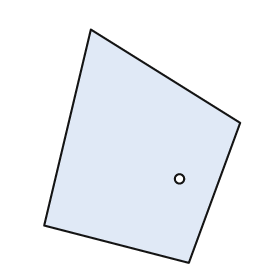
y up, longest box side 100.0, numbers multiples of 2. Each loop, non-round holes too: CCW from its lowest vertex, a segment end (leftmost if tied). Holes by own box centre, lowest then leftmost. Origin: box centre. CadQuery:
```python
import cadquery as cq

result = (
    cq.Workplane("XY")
    .moveTo(20.0, -50.0)
    .lineTo(42.0, 10.0)
    .lineTo(-22.0, 50.0)
    .lineTo(-42.0, -34.0)
    .close()
    .moveTo(16.0, -14.0)
    .circle(2.0)
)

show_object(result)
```